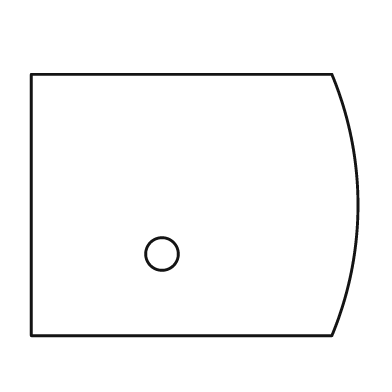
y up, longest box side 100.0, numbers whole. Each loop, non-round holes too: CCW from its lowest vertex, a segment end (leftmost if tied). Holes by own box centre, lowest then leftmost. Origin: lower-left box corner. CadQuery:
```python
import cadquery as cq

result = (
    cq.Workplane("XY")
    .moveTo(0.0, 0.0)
    .lineTo(92.0, 0.0)
    .threePointArc((100.0, 40.0), (92.0, 80.0))
    .lineTo(0.0, 80.0)
    .close()
    .moveTo(40.0, 25.0)
    .circle(5.0)
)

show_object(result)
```